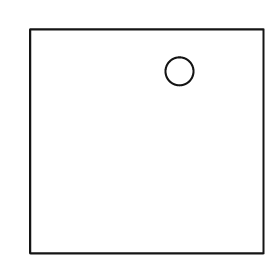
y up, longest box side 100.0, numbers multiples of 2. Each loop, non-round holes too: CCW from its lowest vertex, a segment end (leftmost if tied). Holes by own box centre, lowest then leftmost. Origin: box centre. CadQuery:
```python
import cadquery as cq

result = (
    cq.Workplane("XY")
    .moveTo(-50.0, -48.0)
    .lineTo(50.0, -48.0)
    .lineTo(50.0, 48.0)
    .lineTo(-50.0, 48.0)
    .close()
    .moveTo(14.0, 30.0)
    .circle(6.0)
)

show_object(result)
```